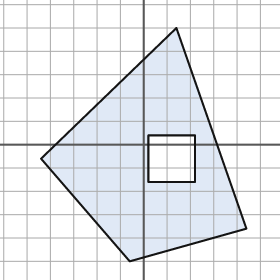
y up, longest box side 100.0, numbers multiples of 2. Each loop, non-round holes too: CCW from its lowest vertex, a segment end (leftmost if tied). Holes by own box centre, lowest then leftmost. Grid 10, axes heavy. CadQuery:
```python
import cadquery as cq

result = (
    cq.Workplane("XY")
    .moveTo(-6.0, -50.0)
    .lineTo(44.0, -36.0)
    .lineTo(14.0, 50.0)
    .lineTo(-44.0, -6.0)
    .close()
    .moveTo(2.0, -16.0)
    .lineTo(22.0, -16.0)
    .lineTo(22.0, 4.0)
    .lineTo(2.0, 4.0)
    .close()
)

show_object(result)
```